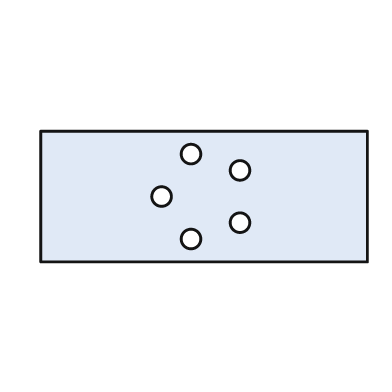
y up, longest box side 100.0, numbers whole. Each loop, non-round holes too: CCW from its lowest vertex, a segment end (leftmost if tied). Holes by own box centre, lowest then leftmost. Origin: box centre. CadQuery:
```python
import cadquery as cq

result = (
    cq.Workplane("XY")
    .moveTo(-50.0, -20.0)
    .lineTo(50.0, -20.0)
    .lineTo(50.0, 20.0)
    .lineTo(-50.0, 20.0)
    .close()
    .moveTo(-4.0, -13.0)
    .circle(3.0)
    .moveTo(11.0, -8.0)
    .circle(3.0)
    .moveTo(-13.0, 0.0)
    .circle(3.0)
    .moveTo(11.0, 8.0)
    .circle(3.0)
    .moveTo(-4.0, 13.0)
    .circle(3.0)
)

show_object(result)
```